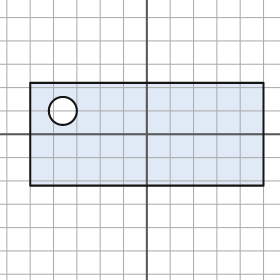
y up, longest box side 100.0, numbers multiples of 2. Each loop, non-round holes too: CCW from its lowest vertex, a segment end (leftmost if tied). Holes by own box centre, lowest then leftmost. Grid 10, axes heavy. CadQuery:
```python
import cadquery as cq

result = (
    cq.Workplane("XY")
    .moveTo(-50.0, -22.0)
    .lineTo(50.0, -22.0)
    .lineTo(50.0, 22.0)
    .lineTo(-50.0, 22.0)
    .close()
    .moveTo(-36.0, 10.0)
    .circle(6.0)
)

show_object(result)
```